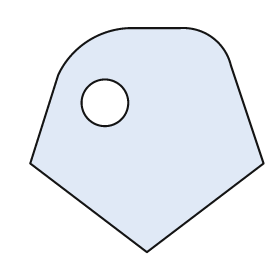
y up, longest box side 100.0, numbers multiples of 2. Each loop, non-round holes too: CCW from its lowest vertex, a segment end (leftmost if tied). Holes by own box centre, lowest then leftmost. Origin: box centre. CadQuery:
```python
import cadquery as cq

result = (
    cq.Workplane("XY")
    .moveTo(0.0, -48.0)
    .lineTo(50.0, -10.0)
    .lineTo(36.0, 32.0)
    .threePointArc((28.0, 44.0), (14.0, 48.0))
    .lineTo(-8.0, 48.0)
    .threePointArc((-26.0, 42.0), (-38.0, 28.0))
    .lineTo(-50.0, -10.0)
    .close()
    .moveTo(-18.0, 16.0)
    .circle(10.0)
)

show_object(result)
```